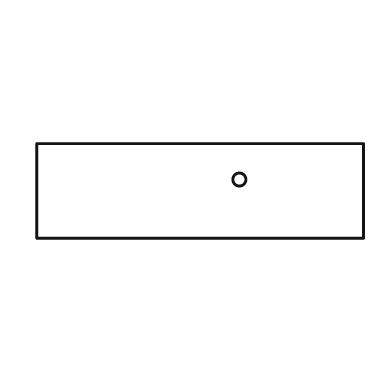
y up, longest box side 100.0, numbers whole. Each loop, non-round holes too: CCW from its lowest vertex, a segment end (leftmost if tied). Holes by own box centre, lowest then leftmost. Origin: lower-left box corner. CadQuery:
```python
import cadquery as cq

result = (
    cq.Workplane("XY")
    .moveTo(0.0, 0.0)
    .lineTo(100.0, 0.0)
    .lineTo(100.0, 29.0)
    .lineTo(0.0, 29.0)
    .close()
    .moveTo(62.0, 18.0)
    .circle(2.0)
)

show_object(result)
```